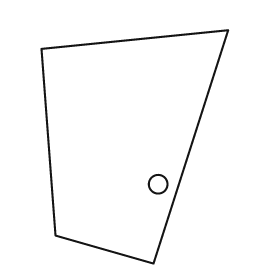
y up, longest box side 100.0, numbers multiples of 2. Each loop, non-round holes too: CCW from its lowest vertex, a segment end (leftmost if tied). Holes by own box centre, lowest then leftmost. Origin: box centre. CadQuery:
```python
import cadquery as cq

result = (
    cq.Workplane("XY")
    .moveTo(8.0, -50.0)
    .lineTo(40.0, 50.0)
    .lineTo(-40.0, 42.0)
    .lineTo(-34.0, -38.0)
    .close()
    .moveTo(10.0, -16.0)
    .circle(4.0)
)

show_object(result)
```